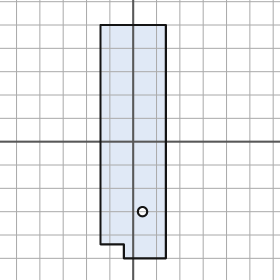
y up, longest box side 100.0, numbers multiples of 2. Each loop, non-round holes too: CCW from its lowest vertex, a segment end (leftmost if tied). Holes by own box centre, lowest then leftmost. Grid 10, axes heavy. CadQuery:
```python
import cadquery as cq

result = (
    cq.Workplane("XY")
    .moveTo(-4.0, -50.0)
    .lineTo(14.0, -50.0)
    .lineTo(14.0, 50.0)
    .lineTo(-14.0, 50.0)
    .lineTo(-14.0, -44.0)
    .lineTo(-4.0, -44.0)
    .close()
    .moveTo(4.0, -30.0)
    .circle(2.0)
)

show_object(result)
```